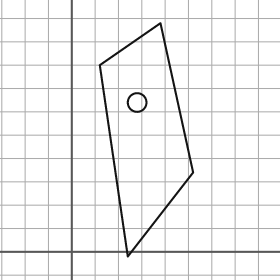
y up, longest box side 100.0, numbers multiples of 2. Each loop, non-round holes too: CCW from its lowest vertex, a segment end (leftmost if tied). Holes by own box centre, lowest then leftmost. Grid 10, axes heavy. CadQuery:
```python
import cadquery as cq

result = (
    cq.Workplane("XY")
    .moveTo(24.0, -2.0)
    .lineTo(52.0, 34.0)
    .lineTo(38.0, 98.0)
    .lineTo(12.0, 80.0)
    .close()
    .moveTo(28.0, 64.0)
    .circle(4.0)
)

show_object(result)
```